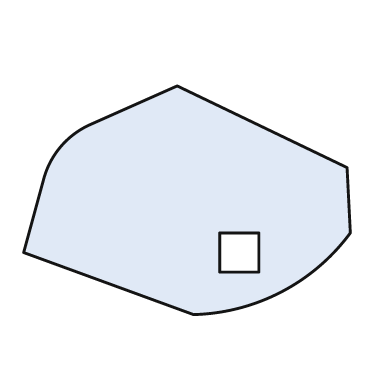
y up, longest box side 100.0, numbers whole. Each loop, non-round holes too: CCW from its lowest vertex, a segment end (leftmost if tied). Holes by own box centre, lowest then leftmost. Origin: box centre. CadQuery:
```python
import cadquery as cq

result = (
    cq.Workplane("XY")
    .moveTo(2.0, -35.0)
    .threePointArc((29.0, -28.0), (50.0, -10.0))
    .lineTo(49.0, 10.0)
    .lineTo(-3.0, 35.0)
    .lineTo(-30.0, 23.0)
    .threePointArc((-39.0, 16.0), (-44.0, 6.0))
    .lineTo(-50.0, -16.0)
    .close()
    .moveTo(10.0, -22.0)
    .lineTo(22.0, -22.0)
    .lineTo(22.0, -10.0)
    .lineTo(10.0, -10.0)
    .close()
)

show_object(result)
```